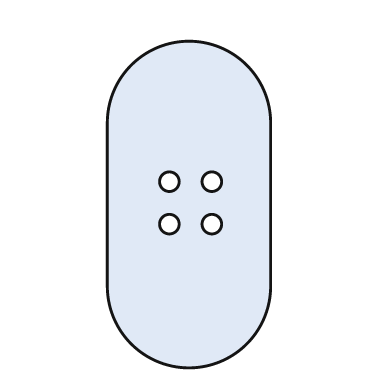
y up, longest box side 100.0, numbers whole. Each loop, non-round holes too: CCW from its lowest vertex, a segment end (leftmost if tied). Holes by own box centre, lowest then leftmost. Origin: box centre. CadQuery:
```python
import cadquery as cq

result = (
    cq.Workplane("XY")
    .moveTo(-25.0, -25.0)
    .threePointArc((0.0, -50.0), (25.0, -25.0))
    .lineTo(25.0, 25.0)
    .threePointArc((0.0, 50.0), (-25.0, 25.0))
    .close()
    .moveTo(-6.0, -6.0)
    .circle(3.0)
    .moveTo(7.0, -6.0)
    .circle(3.0)
    .moveTo(-6.0, 7.0)
    .circle(3.0)
    .moveTo(7.0, 7.0)
    .circle(3.0)
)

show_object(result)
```